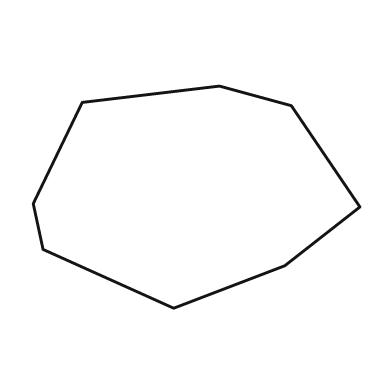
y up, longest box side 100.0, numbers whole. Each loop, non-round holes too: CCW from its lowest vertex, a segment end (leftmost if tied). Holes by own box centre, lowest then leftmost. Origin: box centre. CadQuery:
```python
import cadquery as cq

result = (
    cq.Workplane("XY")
    .moveTo(-7.0, -34.0)
    .lineTo(27.0, -21.0)
    .lineTo(50.0, -3.0)
    .lineTo(29.0, 28.0)
    .lineTo(7.0, 34.0)
    .lineTo(-35.0, 29.0)
    .lineTo(-50.0, -2.0)
    .lineTo(-47.0, -16.0)
    .close()
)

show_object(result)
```